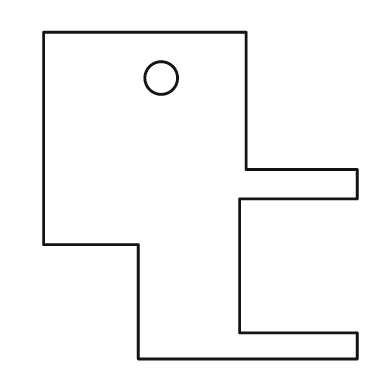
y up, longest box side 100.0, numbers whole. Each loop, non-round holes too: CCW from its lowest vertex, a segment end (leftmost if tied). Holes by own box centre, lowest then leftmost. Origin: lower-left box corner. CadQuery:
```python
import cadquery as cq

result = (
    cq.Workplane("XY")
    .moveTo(29.0, 0.0)
    .lineTo(96.0, 0.0)
    .lineTo(96.0, 8.0)
    .lineTo(60.0, 8.0)
    .lineTo(60.0, 49.0)
    .lineTo(96.0, 49.0)
    .lineTo(96.0, 58.0)
    .lineTo(62.0, 58.0)
    .lineTo(62.0, 100.0)
    .lineTo(0.0, 100.0)
    .lineTo(0.0, 35.0)
    .lineTo(29.0, 35.0)
    .close()
    .moveTo(36.0, 86.0)
    .circle(5.0)
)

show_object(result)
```